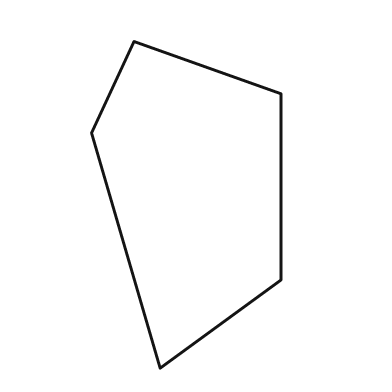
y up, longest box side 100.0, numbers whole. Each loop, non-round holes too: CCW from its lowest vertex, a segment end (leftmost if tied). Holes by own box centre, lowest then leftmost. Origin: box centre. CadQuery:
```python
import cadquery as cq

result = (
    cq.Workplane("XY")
    .moveTo(-8.0, -50.0)
    .lineTo(29.0, -23.0)
    .lineTo(29.0, 34.0)
    .lineTo(-16.0, 50.0)
    .lineTo(-29.0, 22.0)
    .close()
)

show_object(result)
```